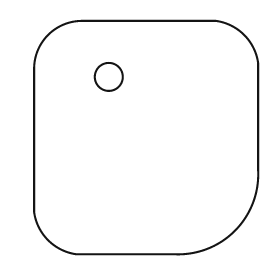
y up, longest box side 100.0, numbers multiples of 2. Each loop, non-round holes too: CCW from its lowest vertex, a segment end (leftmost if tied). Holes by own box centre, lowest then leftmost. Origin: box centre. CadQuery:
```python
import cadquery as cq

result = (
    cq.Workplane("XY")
    .moveTo(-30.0, -50.0)
    .lineTo(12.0, -50.0)
    .threePointArc((38.0, -40.0), (48.0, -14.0))
    .lineTo(48.0, 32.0)
    .threePointArc((42.0, 44.0), (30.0, 50.0))
    .lineTo(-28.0, 50.0)
    .threePointArc((-42.0, 44.0), (-48.0, 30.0))
    .lineTo(-48.0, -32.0)
    .threePointArc((-42.0, -44.0), (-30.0, -50.0))
    .close()
    .moveTo(-16.0, 26.0)
    .circle(6.0)
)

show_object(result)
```